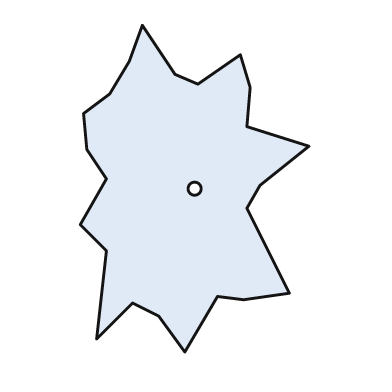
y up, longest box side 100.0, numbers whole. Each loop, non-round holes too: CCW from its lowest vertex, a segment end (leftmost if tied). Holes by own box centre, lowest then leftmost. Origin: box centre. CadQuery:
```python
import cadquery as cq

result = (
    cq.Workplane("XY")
    .moveTo(-3.0, -50.0)
    .lineTo(7.0, -33.0)
    .lineTo(15.0, -34.0)
    .lineTo(29.0, -32.0)
    .lineTo(16.0, -6.0)
    .lineTo(20.0, 1.0)
    .lineTo(35.0, 13.0)
    .lineTo(16.0, 19.0)
    .lineTo(17.0, 31.0)
    .lineTo(14.0, 41.0)
    .lineTo(1.0, 32.0)
    .lineTo(-6.0, 35.0)
    .lineTo(-16.0, 50.0)
    .lineTo(-20.0, 39.0)
    .lineTo(-26.0, 29.0)
    .lineTo(-34.0, 23.0)
    .lineTo(-33.0, 12.0)
    .lineTo(-27.0, 3.0)
    .lineTo(-35.0, -11.0)
    .lineTo(-27.0, -19.0)
    .lineTo(-30.0, -46.0)
    .lineTo(-19.0, -35.0)
    .lineTo(-11.0, -39.0)
    .close()
    .moveTo(0.0, 0.0)
    .circle(2.0)
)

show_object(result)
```